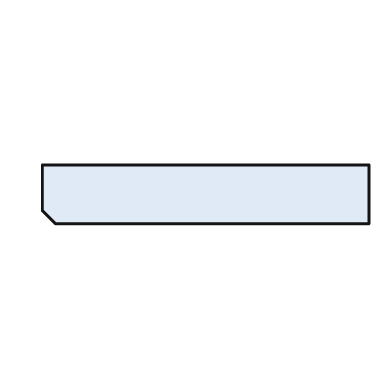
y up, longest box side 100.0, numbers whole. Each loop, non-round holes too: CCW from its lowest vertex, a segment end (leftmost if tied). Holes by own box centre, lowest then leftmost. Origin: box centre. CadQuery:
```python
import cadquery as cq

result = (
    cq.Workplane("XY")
    .moveTo(-46.0, -9.0)
    .lineTo(50.0, -9.0)
    .lineTo(50.0, 9.0)
    .lineTo(-50.0, 9.0)
    .lineTo(-50.0, -5.0)
    .close()
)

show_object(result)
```